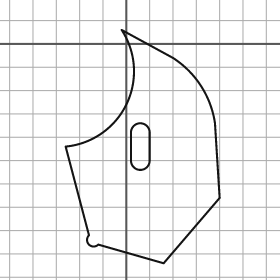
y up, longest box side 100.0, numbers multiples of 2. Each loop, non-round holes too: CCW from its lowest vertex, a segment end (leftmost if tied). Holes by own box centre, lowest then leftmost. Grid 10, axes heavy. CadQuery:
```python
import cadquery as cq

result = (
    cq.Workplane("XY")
    .moveTo(16.0, -94.0)
    .lineTo(40.0, -66.0)
    .lineTo(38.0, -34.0)
    .threePointArc((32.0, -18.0), (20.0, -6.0))
    .lineTo(-2.0, 6.0)
    .threePointArc((0.0, -26.0), (-26.0, -44.0))
    .lineTo(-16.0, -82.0)
    .threePointArc((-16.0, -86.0), (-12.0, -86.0))
    .close()
    .moveTo(2.0, -50.0)
    .threePointArc((6.0, -54.0), (10.0, -50.0))
    .lineTo(10.0, -38.0)
    .threePointArc((6.0, -34.0), (2.0, -38.0))
    .close()
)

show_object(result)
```